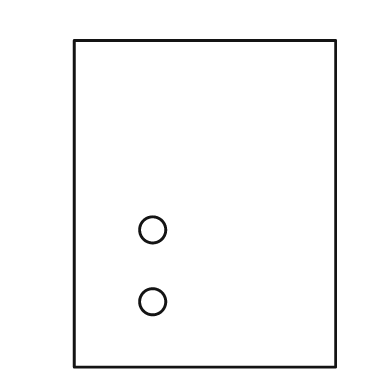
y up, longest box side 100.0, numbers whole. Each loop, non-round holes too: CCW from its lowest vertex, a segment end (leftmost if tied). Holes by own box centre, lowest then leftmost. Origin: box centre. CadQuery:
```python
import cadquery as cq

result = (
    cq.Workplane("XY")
    .moveTo(-40.0, -50.0)
    .lineTo(40.0, -50.0)
    .lineTo(40.0, 50.0)
    .lineTo(-40.0, 50.0)
    .close()
    .moveTo(-16.0, -30.0)
    .circle(4.0)
    .moveTo(-16.0, -8.0)
    .circle(4.0)
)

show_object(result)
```